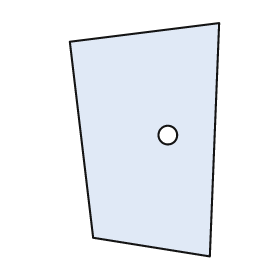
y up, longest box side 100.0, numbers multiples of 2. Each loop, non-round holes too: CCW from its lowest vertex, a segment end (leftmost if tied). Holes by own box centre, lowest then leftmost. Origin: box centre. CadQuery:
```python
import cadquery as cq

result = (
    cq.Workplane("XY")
    .moveTo(28.0, -50.0)
    .lineTo(32.0, 50.0)
    .lineTo(-32.0, 42.0)
    .lineTo(-22.0, -42.0)
    .close()
    .moveTo(10.0, 2.0)
    .circle(4.0)
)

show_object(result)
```